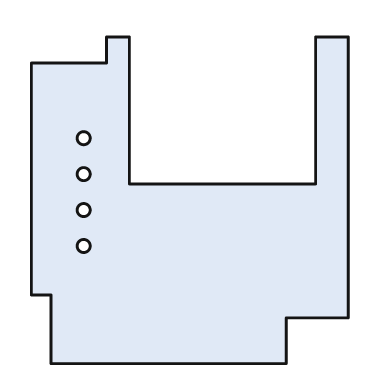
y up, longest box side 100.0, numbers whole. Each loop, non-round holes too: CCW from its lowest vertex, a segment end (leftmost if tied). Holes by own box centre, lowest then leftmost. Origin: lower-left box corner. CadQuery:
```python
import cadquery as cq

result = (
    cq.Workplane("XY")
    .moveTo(6.0, 0.0)
    .lineTo(78.0, 0.0)
    .lineTo(78.0, 14.0)
    .lineTo(97.0, 14.0)
    .lineTo(97.0, 100.0)
    .lineTo(87.0, 100.0)
    .lineTo(87.0, 55.0)
    .lineTo(30.0, 55.0)
    .lineTo(30.0, 100.0)
    .lineTo(23.0, 100.0)
    .lineTo(23.0, 92.0)
    .lineTo(0.0, 92.0)
    .lineTo(0.0, 21.0)
    .lineTo(6.0, 21.0)
    .close()
    .moveTo(16.0, 36.0)
    .circle(2.0)
    .moveTo(16.0, 47.0)
    .circle(2.0)
    .moveTo(16.0, 58.0)
    .circle(2.0)
    .moveTo(16.0, 69.0)
    .circle(2.0)
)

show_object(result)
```